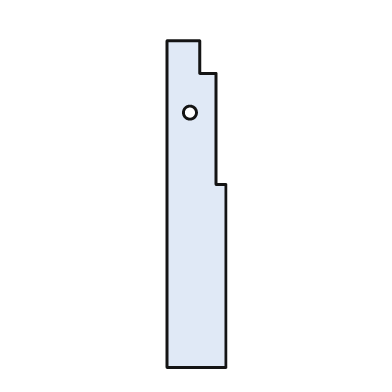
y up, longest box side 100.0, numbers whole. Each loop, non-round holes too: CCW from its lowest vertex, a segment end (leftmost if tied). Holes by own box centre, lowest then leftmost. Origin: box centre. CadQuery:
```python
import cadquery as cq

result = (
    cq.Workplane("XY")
    .moveTo(-9.0, -50.0)
    .lineTo(9.0, -50.0)
    .lineTo(9.0, 6.0)
    .lineTo(6.0, 6.0)
    .lineTo(6.0, 40.0)
    .lineTo(1.0, 40.0)
    .lineTo(1.0, 50.0)
    .lineTo(-9.0, 50.0)
    .close()
    .moveTo(-2.0, 28.0)
    .circle(2.0)
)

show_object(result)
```